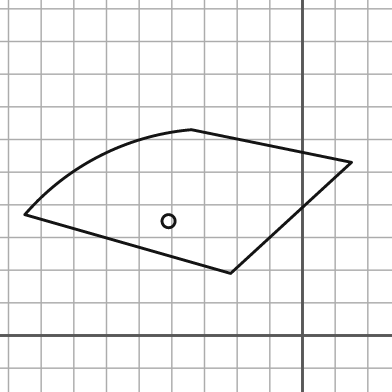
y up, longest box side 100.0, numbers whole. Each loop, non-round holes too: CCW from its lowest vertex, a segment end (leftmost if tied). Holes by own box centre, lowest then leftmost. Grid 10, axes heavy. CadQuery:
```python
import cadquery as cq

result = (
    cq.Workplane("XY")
    .moveTo(-22.0, 19.0)
    .lineTo(15.0, 53.0)
    .lineTo(-34.0, 63.0)
    .threePointArc((-62.0, 55.0), (-85.0, 37.0))
    .close()
    .moveTo(-41.0, 35.0)
    .circle(2.0)
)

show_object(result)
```